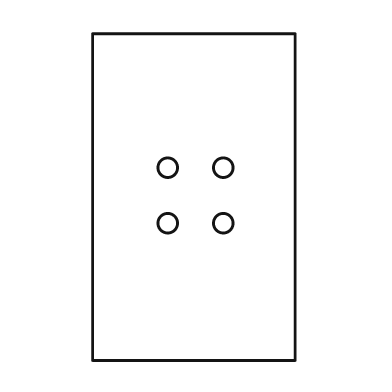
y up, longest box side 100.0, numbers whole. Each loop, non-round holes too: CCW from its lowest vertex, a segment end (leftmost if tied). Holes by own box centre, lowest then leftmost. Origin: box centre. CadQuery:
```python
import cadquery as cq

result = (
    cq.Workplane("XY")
    .moveTo(-31.0, -50.0)
    .lineTo(31.0, -50.0)
    .lineTo(31.0, 50.0)
    .lineTo(-31.0, 50.0)
    .close()
    .moveTo(-8.0, -8.0)
    .circle(3.0)
    .moveTo(9.0, -8.0)
    .circle(3.0)
    .moveTo(-8.0, 9.0)
    .circle(3.0)
    .moveTo(9.0, 9.0)
    .circle(3.0)
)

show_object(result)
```